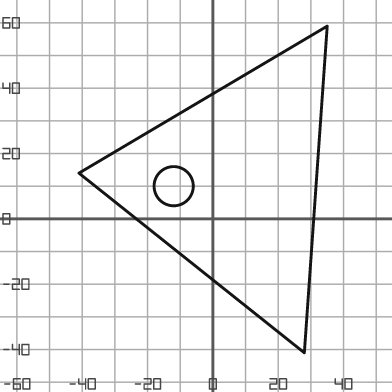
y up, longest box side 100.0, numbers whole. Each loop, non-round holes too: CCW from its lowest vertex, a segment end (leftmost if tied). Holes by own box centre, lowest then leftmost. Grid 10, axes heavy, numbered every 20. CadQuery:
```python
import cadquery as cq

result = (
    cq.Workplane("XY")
    .moveTo(28.0, -41.0)
    .lineTo(35.0, 59.0)
    .lineTo(-41.0, 14.0)
    .close()
    .moveTo(-12.0, 10.0)
    .circle(6.0)
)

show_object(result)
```